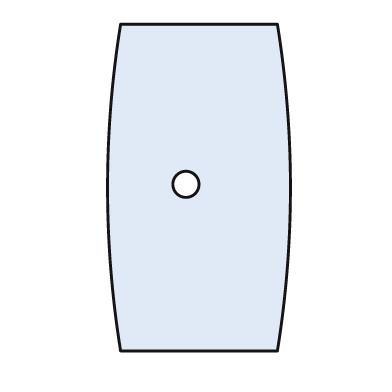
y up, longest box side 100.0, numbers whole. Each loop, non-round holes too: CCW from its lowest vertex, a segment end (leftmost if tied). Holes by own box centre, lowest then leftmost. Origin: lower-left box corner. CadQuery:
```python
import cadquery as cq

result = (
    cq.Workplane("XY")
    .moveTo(4.0, 0.0)
    .lineTo(52.0, 0.0)
    .threePointArc((56.0, 50.0), (52.0, 100.0))
    .lineTo(4.0, 100.0)
    .threePointArc((0.0, 50.0), (4.0, 0.0))
    .close()
    .moveTo(24.0, 51.0)
    .circle(4.0)
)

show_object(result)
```